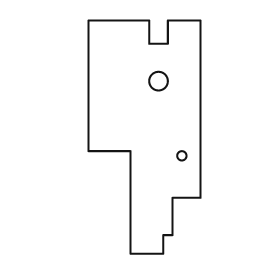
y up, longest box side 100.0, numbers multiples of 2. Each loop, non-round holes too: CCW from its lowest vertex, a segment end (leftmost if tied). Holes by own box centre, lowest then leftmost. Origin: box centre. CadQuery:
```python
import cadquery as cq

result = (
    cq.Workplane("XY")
    .moveTo(-6.0, -50.0)
    .lineTo(8.0, -50.0)
    .lineTo(8.0, -42.0)
    .lineTo(12.0, -42.0)
    .lineTo(12.0, -26.0)
    .lineTo(24.0, -26.0)
    .lineTo(24.0, 50.0)
    .lineTo(10.0, 50.0)
    .lineTo(10.0, 40.0)
    .lineTo(2.0, 40.0)
    .lineTo(2.0, 50.0)
    .lineTo(-24.0, 50.0)
    .lineTo(-24.0, -6.0)
    .lineTo(-6.0, -6.0)
    .close()
    .moveTo(16.0, -8.0)
    .circle(2.0)
    .moveTo(6.0, 24.0)
    .circle(4.0)
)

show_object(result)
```